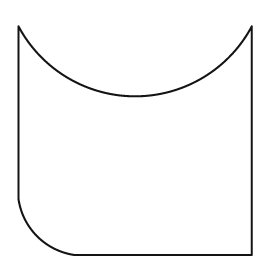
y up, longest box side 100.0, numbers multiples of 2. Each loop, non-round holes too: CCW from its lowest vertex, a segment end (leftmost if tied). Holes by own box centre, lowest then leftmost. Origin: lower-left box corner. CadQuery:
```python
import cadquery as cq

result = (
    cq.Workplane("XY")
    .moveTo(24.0, 0.0)
    .lineTo(100.0, 0.0)
    .lineTo(100.0, 98.0)
    .threePointArc((50.0, 68.0), (0.0, 98.0))
    .lineTo(0.0, 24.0)
    .threePointArc((8.0, 8.0), (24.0, 0.0))
    .close()
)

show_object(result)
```